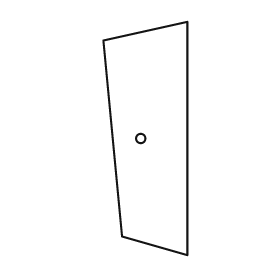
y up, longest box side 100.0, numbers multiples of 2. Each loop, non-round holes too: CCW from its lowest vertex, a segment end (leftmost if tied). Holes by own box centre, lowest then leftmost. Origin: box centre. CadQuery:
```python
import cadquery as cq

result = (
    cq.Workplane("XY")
    .moveTo(18.0, -50.0)
    .lineTo(18.0, 50.0)
    .lineTo(-18.0, 42.0)
    .lineTo(-10.0, -42.0)
    .close()
    .moveTo(-2.0, 0.0)
    .circle(2.0)
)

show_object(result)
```